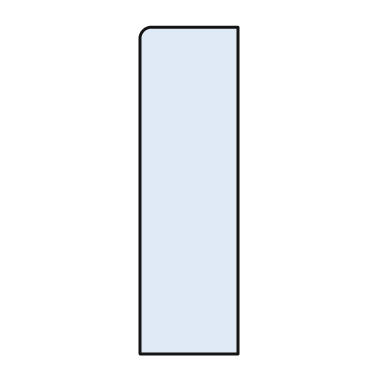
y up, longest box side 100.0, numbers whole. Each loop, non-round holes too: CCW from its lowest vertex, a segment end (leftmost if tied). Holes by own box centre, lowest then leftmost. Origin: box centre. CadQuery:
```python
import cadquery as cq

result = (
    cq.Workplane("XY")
    .moveTo(-15.0, -50.0)
    .lineTo(15.0, -50.0)
    .lineTo(15.0, 50.0)
    .lineTo(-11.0, 50.0)
    .threePointArc((-14.0, 49.0), (-15.0, 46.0))
    .close()
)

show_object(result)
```